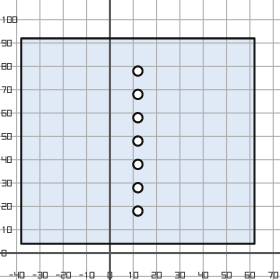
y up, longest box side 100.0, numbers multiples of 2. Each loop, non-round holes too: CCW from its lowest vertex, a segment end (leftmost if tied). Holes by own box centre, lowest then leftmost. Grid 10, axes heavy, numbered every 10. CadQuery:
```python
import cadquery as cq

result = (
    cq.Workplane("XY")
    .moveTo(-38.0, 4.0)
    .lineTo(62.0, 4.0)
    .lineTo(62.0, 92.0)
    .lineTo(-38.0, 92.0)
    .close()
    .moveTo(12.0, 18.0)
    .circle(2.0)
    .moveTo(12.0, 28.0)
    .circle(2.0)
    .moveTo(12.0, 38.0)
    .circle(2.0)
    .moveTo(12.0, 48.0)
    .circle(2.0)
    .moveTo(12.0, 58.0)
    .circle(2.0)
    .moveTo(12.0, 68.0)
    .circle(2.0)
    .moveTo(12.0, 78.0)
    .circle(2.0)
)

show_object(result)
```